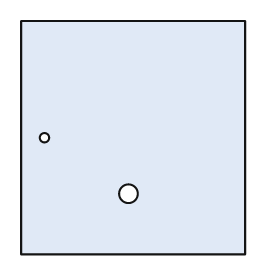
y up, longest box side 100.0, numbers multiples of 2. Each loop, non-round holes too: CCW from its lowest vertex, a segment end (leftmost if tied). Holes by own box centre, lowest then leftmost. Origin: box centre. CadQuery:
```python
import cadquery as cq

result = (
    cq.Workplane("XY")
    .moveTo(-48.0, -50.0)
    .lineTo(48.0, -50.0)
    .lineTo(48.0, 50.0)
    .lineTo(-48.0, 50.0)
    .close()
    .moveTo(-2.0, -24.0)
    .circle(4.0)
    .moveTo(-38.0, 0.0)
    .circle(2.0)
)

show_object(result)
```